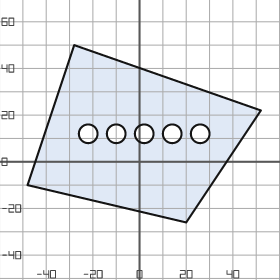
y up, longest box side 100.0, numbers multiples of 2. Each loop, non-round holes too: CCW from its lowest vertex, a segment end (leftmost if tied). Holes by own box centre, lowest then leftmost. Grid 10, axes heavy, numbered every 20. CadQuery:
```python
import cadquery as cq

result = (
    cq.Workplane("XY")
    .moveTo(20.0, -26.0)
    .lineTo(52.0, 22.0)
    .lineTo(-28.0, 50.0)
    .lineTo(-48.0, -10.0)
    .close()
    .moveTo(-22.0, 12.0)
    .circle(4.0)
    .moveTo(-10.0, 12.0)
    .circle(4.0)
    .moveTo(2.0, 12.0)
    .circle(4.0)
    .moveTo(14.0, 12.0)
    .circle(4.0)
    .moveTo(26.0, 12.0)
    .circle(4.0)
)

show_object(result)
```